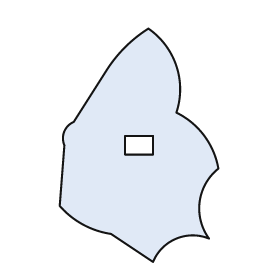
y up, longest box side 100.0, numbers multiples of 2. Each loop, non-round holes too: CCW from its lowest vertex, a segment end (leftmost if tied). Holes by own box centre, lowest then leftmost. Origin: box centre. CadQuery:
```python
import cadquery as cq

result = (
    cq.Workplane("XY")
    .moveTo(6.0, -50.0)
    .threePointArc((16.0, -40.0), (30.0, -40.0))
    .threePointArc((26.0, -24.0), (34.0, -10.0))
    .threePointArc((28.0, 4.0), (16.0, 14.0))
    .threePointArc((16.0, 34.0), (4.0, 50.0))
    .threePointArc((-6.0, 42.0), (-14.0, 32.0))
    .lineTo(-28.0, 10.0)
    .threePointArc((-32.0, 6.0), (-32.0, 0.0))
    .lineTo(-34.0, -26.0)
    .threePointArc((-24.0, -34.0), (-12.0, -38.0))
    .close()
    .moveTo(-6.0, -4.0)
    .lineTo(6.0, -4.0)
    .lineTo(6.0, 4.0)
    .lineTo(-6.0, 4.0)
    .close()
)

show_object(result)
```